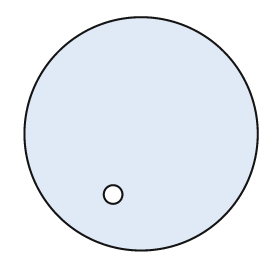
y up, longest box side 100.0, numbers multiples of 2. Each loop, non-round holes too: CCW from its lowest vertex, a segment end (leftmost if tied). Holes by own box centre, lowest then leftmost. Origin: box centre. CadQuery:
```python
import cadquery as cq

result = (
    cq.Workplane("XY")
    .moveTo(0.0, 0.0)
    .circle(50.0)
    .moveTo(-12.0, -26.0)
    .circle(4.0)
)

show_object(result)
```